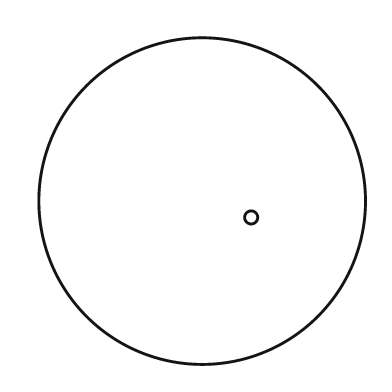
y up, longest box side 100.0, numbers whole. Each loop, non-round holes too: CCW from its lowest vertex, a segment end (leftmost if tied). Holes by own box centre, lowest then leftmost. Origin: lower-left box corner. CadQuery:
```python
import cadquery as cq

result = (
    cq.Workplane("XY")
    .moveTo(50.0, 50.0)
    .circle(50.0)
    .moveTo(65.0, 45.0)
    .circle(2.0)
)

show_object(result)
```